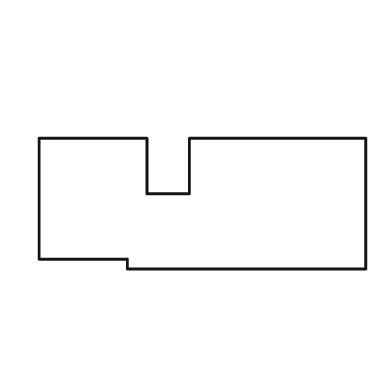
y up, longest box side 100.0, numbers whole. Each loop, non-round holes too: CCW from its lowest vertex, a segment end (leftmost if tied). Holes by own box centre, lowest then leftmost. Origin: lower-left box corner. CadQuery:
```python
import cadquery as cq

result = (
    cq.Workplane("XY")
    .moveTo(27.0, 0.0)
    .lineTo(100.0, 0.0)
    .lineTo(100.0, 40.0)
    .lineTo(46.0, 40.0)
    .lineTo(46.0, 23.0)
    .lineTo(33.0, 23.0)
    .lineTo(33.0, 40.0)
    .lineTo(0.0, 40.0)
    .lineTo(0.0, 3.0)
    .lineTo(27.0, 3.0)
    .close()
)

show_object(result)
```